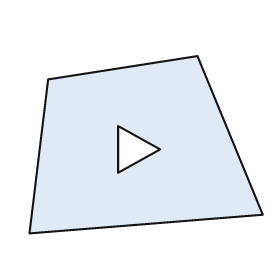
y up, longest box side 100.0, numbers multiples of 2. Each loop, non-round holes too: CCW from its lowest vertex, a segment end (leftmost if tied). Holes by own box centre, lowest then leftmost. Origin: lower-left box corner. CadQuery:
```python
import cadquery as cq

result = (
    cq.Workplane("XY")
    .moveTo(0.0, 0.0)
    .lineTo(100.0, 8.0)
    .lineTo(72.0, 76.0)
    .lineTo(8.0, 66.0)
    .close()
    .moveTo(38.0, 26.0)
    .lineTo(56.0, 36.0)
    .lineTo(38.0, 46.0)
    .close()
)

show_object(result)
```